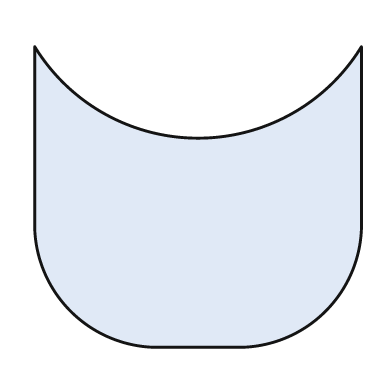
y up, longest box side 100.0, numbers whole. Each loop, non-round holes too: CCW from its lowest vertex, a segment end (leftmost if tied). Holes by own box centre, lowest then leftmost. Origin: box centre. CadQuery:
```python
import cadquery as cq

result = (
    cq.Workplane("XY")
    .moveTo(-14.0, -46.0)
    .lineTo(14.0, -46.0)
    .threePointArc((39.0, -35.0), (50.0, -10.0))
    .lineTo(50.0, 46.0)
    .threePointArc((0.0, 18.0), (-50.0, 46.0))
    .lineTo(-50.0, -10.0)
    .threePointArc((-39.0, -35.0), (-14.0, -46.0))
    .close()
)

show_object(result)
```